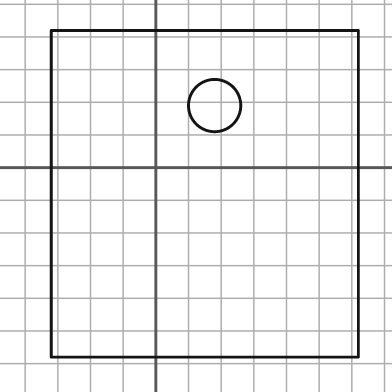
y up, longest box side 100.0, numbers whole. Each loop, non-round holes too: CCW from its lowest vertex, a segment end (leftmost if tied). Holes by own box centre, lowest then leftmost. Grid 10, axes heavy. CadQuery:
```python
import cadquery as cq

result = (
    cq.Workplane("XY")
    .moveTo(-32.0, -58.0)
    .lineTo(62.0, -58.0)
    .lineTo(62.0, 42.0)
    .lineTo(-32.0, 42.0)
    .close()
    .moveTo(18.0, 19.0)
    .circle(8.0)
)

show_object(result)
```